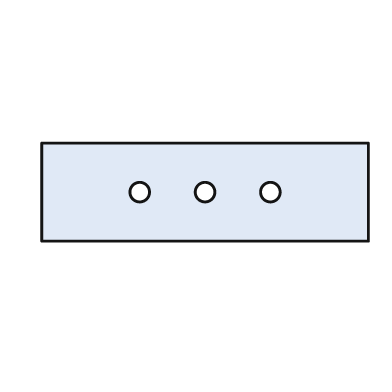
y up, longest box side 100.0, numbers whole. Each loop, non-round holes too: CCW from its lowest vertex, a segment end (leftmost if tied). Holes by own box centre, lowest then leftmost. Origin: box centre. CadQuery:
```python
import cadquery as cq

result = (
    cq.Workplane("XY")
    .moveTo(-50.0, -15.0)
    .lineTo(50.0, -15.0)
    .lineTo(50.0, 15.0)
    .lineTo(-50.0, 15.0)
    .close()
    .moveTo(-20.0, 0.0)
    .circle(3.0)
    .moveTo(0.0, 0.0)
    .circle(3.0)
    .moveTo(20.0, 0.0)
    .circle(3.0)
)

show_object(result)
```